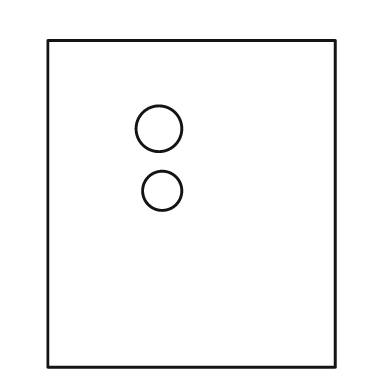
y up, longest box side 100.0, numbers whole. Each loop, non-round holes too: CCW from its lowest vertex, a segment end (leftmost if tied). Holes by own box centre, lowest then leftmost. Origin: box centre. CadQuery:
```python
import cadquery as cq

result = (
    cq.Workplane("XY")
    .moveTo(-44.0, -50.0)
    .lineTo(44.0, -50.0)
    .lineTo(44.0, 50.0)
    .lineTo(-44.0, 50.0)
    .close()
    .moveTo(-9.0, 4.0)
    .circle(6.0)
    .moveTo(-10.0, 23.0)
    .circle(7.0)
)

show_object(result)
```